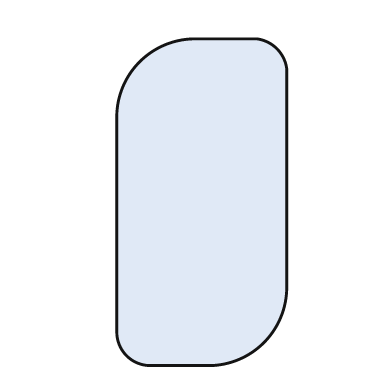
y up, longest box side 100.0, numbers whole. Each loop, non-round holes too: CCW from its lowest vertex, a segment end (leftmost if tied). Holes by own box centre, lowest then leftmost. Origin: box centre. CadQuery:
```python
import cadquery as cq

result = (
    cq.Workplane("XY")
    .moveTo(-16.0, -50.0)
    .lineTo(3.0, -50.0)
    .threePointArc((19.0, -43.0), (26.0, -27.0))
    .lineTo(26.0, 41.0)
    .threePointArc((23.0, 47.0), (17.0, 50.0))
    .lineTo(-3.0, 50.0)
    .threePointArc((-19.0, 43.0), (-26.0, 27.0))
    .lineTo(-26.0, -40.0)
    .threePointArc((-23.0, -47.0), (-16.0, -50.0))
    .close()
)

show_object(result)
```